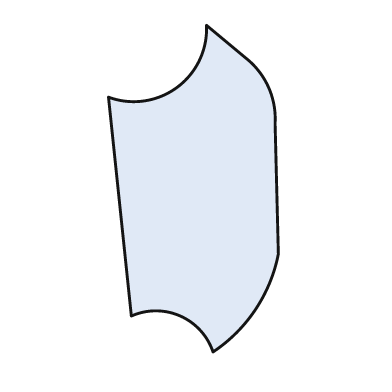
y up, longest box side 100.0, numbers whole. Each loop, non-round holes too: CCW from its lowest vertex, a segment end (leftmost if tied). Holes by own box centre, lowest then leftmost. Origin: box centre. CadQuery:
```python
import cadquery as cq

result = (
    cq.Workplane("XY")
    .moveTo(6.0, -50.0)
    .threePointArc((19.0, -37.0), (26.0, -20.0))
    .lineTo(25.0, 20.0)
    .threePointArc((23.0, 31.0), (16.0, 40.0))
    .lineTo(4.0, 50.0)
    .threePointArc((-5.0, 31.0), (-26.0, 28.0))
    .lineTo(-19.0, -39.0)
    .threePointArc((-4.0, -39.0), (6.0, -50.0))
    .close()
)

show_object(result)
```